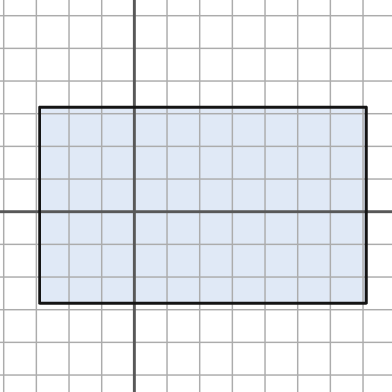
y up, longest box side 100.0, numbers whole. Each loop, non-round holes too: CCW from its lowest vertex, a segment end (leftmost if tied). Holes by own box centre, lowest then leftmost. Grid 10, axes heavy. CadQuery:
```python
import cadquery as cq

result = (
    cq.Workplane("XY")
    .moveTo(-29.0, -28.0)
    .lineTo(71.0, -28.0)
    .lineTo(71.0, 32.0)
    .lineTo(-29.0, 32.0)
    .close()
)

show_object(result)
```